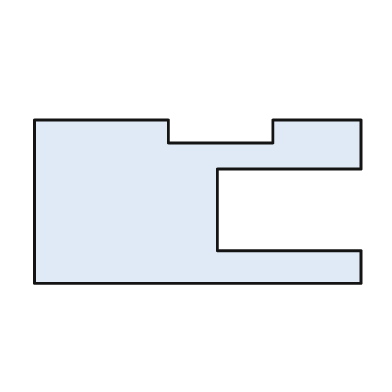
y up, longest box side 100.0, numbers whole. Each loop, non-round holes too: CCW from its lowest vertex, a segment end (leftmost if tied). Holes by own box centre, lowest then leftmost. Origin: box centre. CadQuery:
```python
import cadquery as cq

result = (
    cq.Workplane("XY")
    .moveTo(-50.0, -25.0)
    .lineTo(50.0, -25.0)
    .lineTo(50.0, -15.0)
    .lineTo(6.0, -15.0)
    .lineTo(6.0, 10.0)
    .lineTo(50.0, 10.0)
    .lineTo(50.0, 25.0)
    .lineTo(23.0, 25.0)
    .lineTo(23.0, 18.0)
    .lineTo(-9.0, 18.0)
    .lineTo(-9.0, 25.0)
    .lineTo(-50.0, 25.0)
    .close()
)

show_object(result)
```